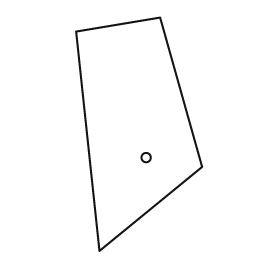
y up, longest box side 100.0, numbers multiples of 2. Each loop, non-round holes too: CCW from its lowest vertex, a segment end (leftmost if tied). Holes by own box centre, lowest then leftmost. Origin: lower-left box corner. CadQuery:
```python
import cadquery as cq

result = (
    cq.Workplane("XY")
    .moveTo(10.0, 0.0)
    .lineTo(54.0, 36.0)
    .lineTo(36.0, 100.0)
    .lineTo(0.0, 94.0)
    .close()
    .moveTo(30.0, 40.0)
    .circle(2.0)
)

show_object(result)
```